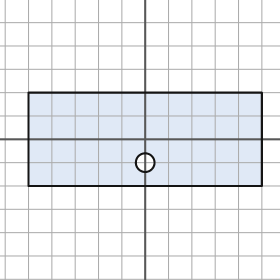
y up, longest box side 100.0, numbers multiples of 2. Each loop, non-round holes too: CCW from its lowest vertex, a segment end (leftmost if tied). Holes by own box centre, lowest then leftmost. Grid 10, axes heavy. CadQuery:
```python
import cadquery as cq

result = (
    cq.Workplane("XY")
    .moveTo(-50.0, -20.0)
    .lineTo(50.0, -20.0)
    .lineTo(50.0, 20.0)
    .lineTo(-50.0, 20.0)
    .close()
    .moveTo(0.0, -10.0)
    .circle(4.0)
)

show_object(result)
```